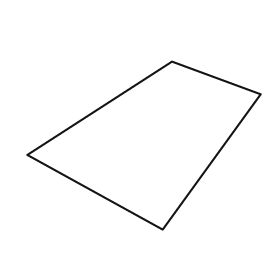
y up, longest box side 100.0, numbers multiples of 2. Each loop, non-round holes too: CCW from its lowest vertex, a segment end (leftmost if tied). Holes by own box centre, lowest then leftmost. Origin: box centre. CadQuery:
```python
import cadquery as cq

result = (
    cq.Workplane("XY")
    .moveTo(8.0, -36.0)
    .lineTo(50.0, 22.0)
    .lineTo(12.0, 36.0)
    .lineTo(-50.0, -4.0)
    .close()
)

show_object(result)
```